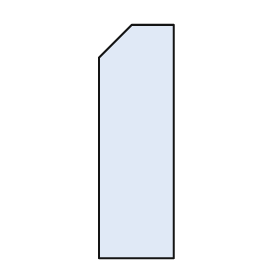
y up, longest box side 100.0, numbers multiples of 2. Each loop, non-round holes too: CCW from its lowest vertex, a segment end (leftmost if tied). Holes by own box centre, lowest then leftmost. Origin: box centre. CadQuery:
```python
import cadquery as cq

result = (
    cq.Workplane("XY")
    .moveTo(-16.0, -50.0)
    .lineTo(16.0, -50.0)
    .lineTo(16.0, 50.0)
    .lineTo(-2.0, 50.0)
    .lineTo(-16.0, 36.0)
    .close()
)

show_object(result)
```